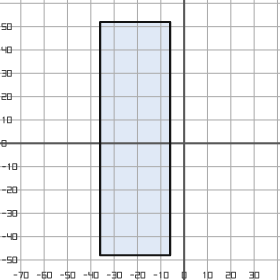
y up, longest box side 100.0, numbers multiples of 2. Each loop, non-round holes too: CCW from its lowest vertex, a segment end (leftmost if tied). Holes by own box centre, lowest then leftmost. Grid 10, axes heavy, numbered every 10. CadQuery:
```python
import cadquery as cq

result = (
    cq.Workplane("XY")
    .moveTo(-36.0, -48.0)
    .lineTo(-6.0, -48.0)
    .lineTo(-6.0, 52.0)
    .lineTo(-36.0, 52.0)
    .close()
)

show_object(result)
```